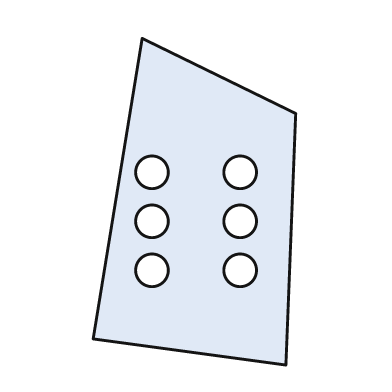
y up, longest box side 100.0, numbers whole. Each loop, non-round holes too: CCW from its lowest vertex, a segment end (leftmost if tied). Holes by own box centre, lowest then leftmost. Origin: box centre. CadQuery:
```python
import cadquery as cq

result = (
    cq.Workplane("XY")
    .moveTo(28.0, -50.0)
    .lineTo(31.0, 27.0)
    .lineTo(-16.0, 50.0)
    .lineTo(-31.0, -42.0)
    .close()
    .moveTo(-13.0, -21.0)
    .circle(5.0)
    .moveTo(14.0, -21.0)
    .circle(5.0)
    .moveTo(-13.0, -6.0)
    .circle(5.0)
    .moveTo(14.0, -6.0)
    .circle(5.0)
    .moveTo(-13.0, 9.0)
    .circle(5.0)
    .moveTo(14.0, 9.0)
    .circle(5.0)
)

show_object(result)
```